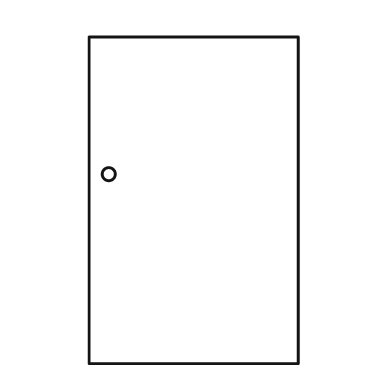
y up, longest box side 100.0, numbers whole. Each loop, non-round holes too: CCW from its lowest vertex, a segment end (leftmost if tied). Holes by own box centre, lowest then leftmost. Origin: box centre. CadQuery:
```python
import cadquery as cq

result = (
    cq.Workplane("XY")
    .moveTo(-32.0, -50.0)
    .lineTo(32.0, -50.0)
    .lineTo(32.0, 50.0)
    .lineTo(-32.0, 50.0)
    .close()
    .moveTo(-26.0, 8.0)
    .circle(2.0)
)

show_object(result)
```